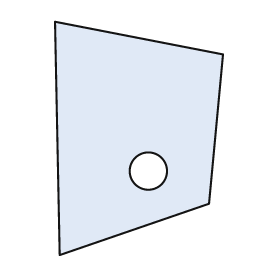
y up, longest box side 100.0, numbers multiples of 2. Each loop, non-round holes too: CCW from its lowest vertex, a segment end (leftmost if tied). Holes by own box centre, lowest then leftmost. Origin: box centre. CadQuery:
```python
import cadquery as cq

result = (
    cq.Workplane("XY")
    .moveTo(-34.0, -50.0)
    .lineTo(30.0, -28.0)
    .lineTo(36.0, 36.0)
    .lineTo(-36.0, 50.0)
    .close()
    .moveTo(4.0, -14.0)
    .circle(8.0)
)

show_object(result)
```